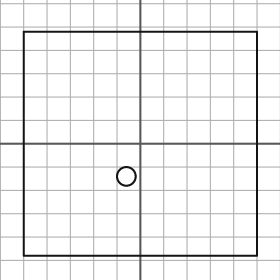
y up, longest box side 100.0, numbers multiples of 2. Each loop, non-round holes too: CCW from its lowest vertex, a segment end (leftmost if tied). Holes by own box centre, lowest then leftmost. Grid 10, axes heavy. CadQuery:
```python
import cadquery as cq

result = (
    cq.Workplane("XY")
    .moveTo(-50.0, -48.0)
    .lineTo(50.0, -48.0)
    .lineTo(50.0, 48.0)
    .lineTo(-50.0, 48.0)
    .close()
    .moveTo(-6.0, -14.0)
    .circle(4.0)
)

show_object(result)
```